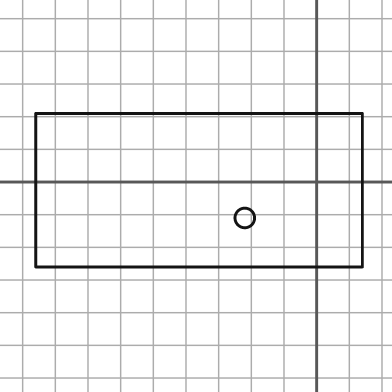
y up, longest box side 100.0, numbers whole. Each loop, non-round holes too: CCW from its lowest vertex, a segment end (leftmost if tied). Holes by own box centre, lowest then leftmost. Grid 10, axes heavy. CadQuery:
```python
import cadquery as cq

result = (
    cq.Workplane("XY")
    .moveTo(-86.0, -26.0)
    .lineTo(14.0, -26.0)
    .lineTo(14.0, 21.0)
    .lineTo(-86.0, 21.0)
    .close()
    .moveTo(-22.0, -11.0)
    .circle(3.0)
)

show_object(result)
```